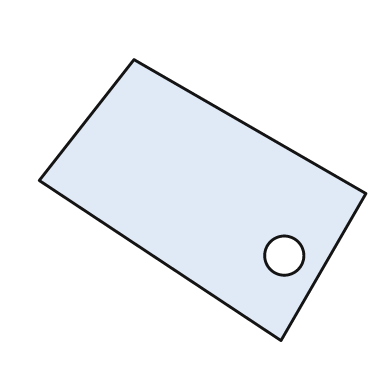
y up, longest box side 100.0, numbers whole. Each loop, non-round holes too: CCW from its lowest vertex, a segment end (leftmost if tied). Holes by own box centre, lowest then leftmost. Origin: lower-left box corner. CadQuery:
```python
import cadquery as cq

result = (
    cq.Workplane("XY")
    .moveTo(74.0, 0.0)
    .lineTo(100.0, 45.0)
    .lineTo(29.0, 86.0)
    .lineTo(0.0, 49.0)
    .close()
    .moveTo(75.0, 26.0)
    .circle(6.0)
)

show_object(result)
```